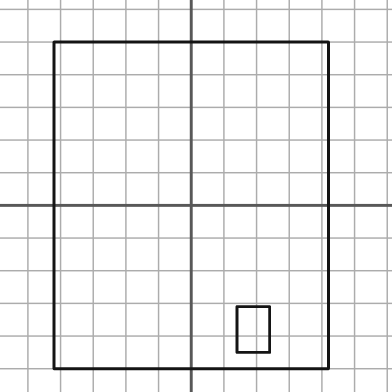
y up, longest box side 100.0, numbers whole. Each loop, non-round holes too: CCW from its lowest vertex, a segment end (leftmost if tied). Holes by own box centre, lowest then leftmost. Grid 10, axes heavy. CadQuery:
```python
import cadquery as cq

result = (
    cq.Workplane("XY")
    .moveTo(-42.0, -50.0)
    .lineTo(42.0, -50.0)
    .lineTo(42.0, 50.0)
    .lineTo(-42.0, 50.0)
    .close()
    .moveTo(14.0, -45.0)
    .lineTo(24.0, -45.0)
    .lineTo(24.0, -31.0)
    .lineTo(14.0, -31.0)
    .close()
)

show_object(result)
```